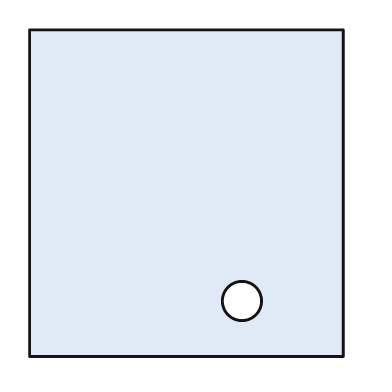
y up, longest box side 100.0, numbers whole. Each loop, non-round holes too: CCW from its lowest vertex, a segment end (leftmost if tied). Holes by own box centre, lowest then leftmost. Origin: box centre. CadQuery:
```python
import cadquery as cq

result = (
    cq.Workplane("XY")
    .moveTo(-48.0, -50.0)
    .lineTo(48.0, -50.0)
    .lineTo(48.0, 50.0)
    .lineTo(-48.0, 50.0)
    .close()
    .moveTo(17.0, -33.0)
    .circle(6.0)
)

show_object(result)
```